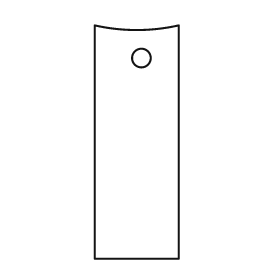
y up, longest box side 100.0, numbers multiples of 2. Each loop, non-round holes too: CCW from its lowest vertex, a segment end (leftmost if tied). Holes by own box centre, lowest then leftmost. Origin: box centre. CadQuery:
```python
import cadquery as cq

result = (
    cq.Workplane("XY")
    .moveTo(-18.0, -50.0)
    .lineTo(18.0, -50.0)
    .lineTo(18.0, 50.0)
    .threePointArc((0.0, 48.0), (-18.0, 50.0))
    .close()
    .moveTo(2.0, 36.0)
    .circle(4.0)
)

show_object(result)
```